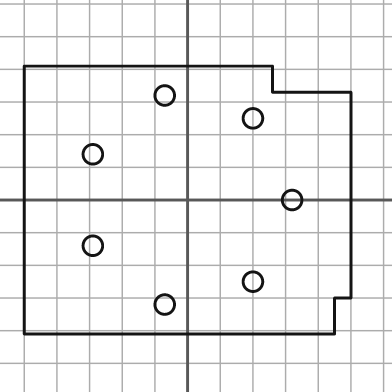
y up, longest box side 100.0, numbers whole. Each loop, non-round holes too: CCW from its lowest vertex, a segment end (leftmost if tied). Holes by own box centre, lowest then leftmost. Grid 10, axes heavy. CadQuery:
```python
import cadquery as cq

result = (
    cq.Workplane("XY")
    .moveTo(-50.0, -41.0)
    .lineTo(45.0, -41.0)
    .lineTo(45.0, -30.0)
    .lineTo(50.0, -30.0)
    .lineTo(50.0, 33.0)
    .lineTo(26.0, 33.0)
    .lineTo(26.0, 41.0)
    .lineTo(-50.0, 41.0)
    .close()
    .moveTo(-7.0, -32.0)
    .circle(3.0)
    .moveTo(20.0, -25.0)
    .circle(3.0)
    .moveTo(-29.0, -14.0)
    .circle(3.0)
    .moveTo(32.0, 0.0)
    .circle(3.0)
    .moveTo(-29.0, 14.0)
    .circle(3.0)
    .moveTo(20.0, 25.0)
    .circle(3.0)
    .moveTo(-7.0, 32.0)
    .circle(3.0)
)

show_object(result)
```